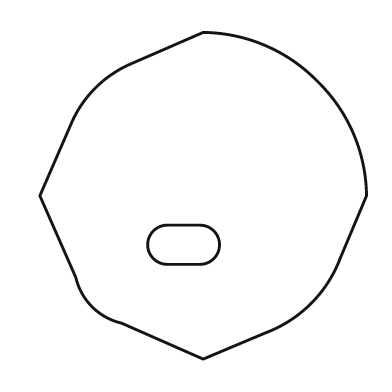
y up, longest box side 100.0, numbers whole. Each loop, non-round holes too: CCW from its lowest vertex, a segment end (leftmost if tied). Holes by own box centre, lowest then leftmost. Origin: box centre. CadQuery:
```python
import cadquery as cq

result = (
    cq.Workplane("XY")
    .moveTo(0.0, -50.0)
    .lineTo(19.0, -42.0)
    .threePointArc((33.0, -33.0), (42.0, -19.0))
    .lineTo(50.0, 0.0)
    .threePointArc((46.0, 19.0), (35.0, 35.0))
    .threePointArc((19.0, 46.0), (0.0, 50.0))
    .lineTo(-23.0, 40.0)
    .threePointArc((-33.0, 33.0), (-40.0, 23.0))
    .lineTo(-50.0, 0.0)
    .lineTo(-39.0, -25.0)
    .threePointArc((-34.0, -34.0), (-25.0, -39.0))
    .close()
    .moveTo(-11.0, -21.0)
    .lineTo(-1.0, -21.0)
    .threePointArc((5.0, -15.0), (-1.0, -9.0))
    .lineTo(-11.0, -9.0)
    .threePointArc((-17.0, -15.0), (-11.0, -21.0))
    .close()
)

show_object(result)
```